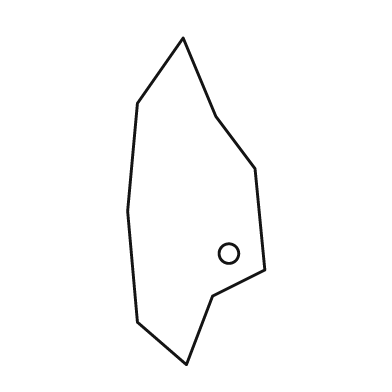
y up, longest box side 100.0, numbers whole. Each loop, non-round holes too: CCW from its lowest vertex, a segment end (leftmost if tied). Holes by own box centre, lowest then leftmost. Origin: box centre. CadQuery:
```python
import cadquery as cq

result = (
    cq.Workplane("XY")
    .moveTo(-3.0, -50.0)
    .lineTo(5.0, -29.0)
    .lineTo(21.0, -21.0)
    .lineTo(18.0, 10.0)
    .lineTo(6.0, 26.0)
    .lineTo(-4.0, 50.0)
    .lineTo(-18.0, 30.0)
    .lineTo(-21.0, -3.0)
    .lineTo(-18.0, -37.0)
    .close()
    .moveTo(10.0, -16.0)
    .circle(3.0)
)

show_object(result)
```